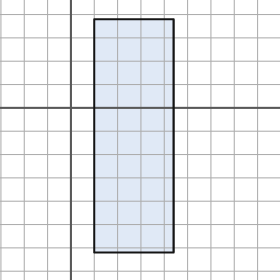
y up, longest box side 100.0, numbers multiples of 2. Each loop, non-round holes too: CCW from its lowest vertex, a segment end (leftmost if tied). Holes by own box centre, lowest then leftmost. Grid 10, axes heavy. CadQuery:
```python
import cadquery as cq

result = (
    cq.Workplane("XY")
    .moveTo(10.0, -62.0)
    .lineTo(44.0, -62.0)
    .lineTo(44.0, 38.0)
    .lineTo(10.0, 38.0)
    .close()
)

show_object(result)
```